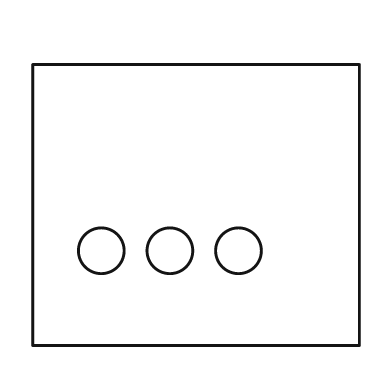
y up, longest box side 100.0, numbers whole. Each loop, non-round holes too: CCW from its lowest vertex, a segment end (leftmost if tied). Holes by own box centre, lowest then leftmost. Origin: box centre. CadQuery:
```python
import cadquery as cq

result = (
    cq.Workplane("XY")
    .moveTo(-50.0, -43.0)
    .lineTo(50.0, -43.0)
    .lineTo(50.0, 43.0)
    .lineTo(-50.0, 43.0)
    .close()
    .moveTo(-29.0, -14.0)
    .circle(7.0)
    .moveTo(-8.0, -14.0)
    .circle(7.0)
    .moveTo(13.0, -14.0)
    .circle(7.0)
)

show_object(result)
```